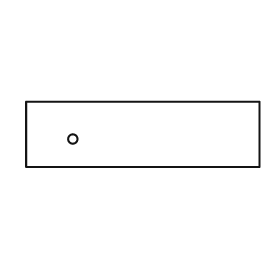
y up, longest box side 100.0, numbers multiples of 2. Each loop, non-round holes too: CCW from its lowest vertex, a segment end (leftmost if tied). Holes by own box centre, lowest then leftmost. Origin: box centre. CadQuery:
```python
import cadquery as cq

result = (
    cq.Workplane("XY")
    .moveTo(-50.0, -14.0)
    .lineTo(50.0, -14.0)
    .lineTo(50.0, 14.0)
    .lineTo(-50.0, 14.0)
    .close()
    .moveTo(-30.0, -2.0)
    .circle(2.0)
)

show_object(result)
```